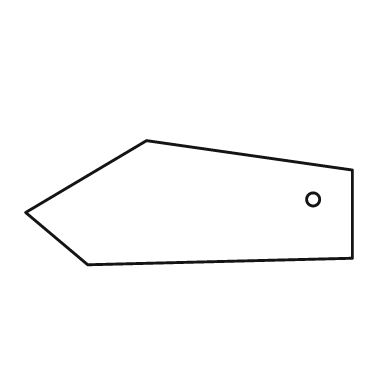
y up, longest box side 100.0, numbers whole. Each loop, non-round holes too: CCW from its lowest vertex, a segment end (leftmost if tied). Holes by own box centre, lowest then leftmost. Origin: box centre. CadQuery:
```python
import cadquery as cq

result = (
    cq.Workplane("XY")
    .moveTo(-31.0, -19.0)
    .lineTo(50.0, -17.0)
    .lineTo(50.0, 10.0)
    .lineTo(-13.0, 19.0)
    .lineTo(-50.0, -3.0)
    .close()
    .moveTo(38.0, 1.0)
    .circle(2.0)
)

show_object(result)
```